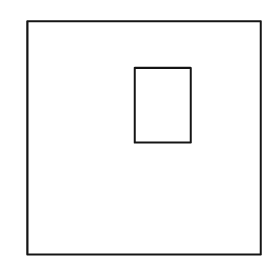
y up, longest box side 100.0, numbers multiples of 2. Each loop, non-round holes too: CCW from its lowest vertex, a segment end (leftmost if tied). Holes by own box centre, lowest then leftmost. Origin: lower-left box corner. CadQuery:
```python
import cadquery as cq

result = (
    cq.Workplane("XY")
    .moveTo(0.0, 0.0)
    .lineTo(100.0, 0.0)
    .lineTo(100.0, 100.0)
    .lineTo(0.0, 100.0)
    .close()
    .moveTo(46.0, 48.0)
    .lineTo(70.0, 48.0)
    .lineTo(70.0, 80.0)
    .lineTo(46.0, 80.0)
    .close()
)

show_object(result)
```